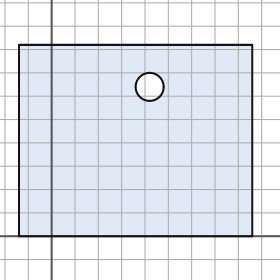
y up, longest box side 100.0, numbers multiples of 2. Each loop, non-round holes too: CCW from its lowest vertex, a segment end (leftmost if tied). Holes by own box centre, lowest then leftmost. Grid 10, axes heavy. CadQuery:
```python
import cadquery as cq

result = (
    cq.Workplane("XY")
    .moveTo(-14.0, 0.0)
    .lineTo(86.0, 0.0)
    .lineTo(86.0, 82.0)
    .lineTo(-14.0, 82.0)
    .close()
    .moveTo(42.0, 64.0)
    .circle(6.0)
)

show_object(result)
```